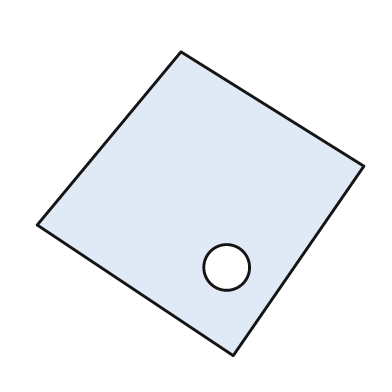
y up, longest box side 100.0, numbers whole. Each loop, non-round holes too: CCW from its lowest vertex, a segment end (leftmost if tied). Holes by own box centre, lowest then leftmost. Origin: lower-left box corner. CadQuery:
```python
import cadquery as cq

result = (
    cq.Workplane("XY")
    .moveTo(60.0, 0.0)
    .lineTo(100.0, 58.0)
    .lineTo(44.0, 93.0)
    .lineTo(0.0, 40.0)
    .close()
    .moveTo(58.0, 27.0)
    .circle(7.0)
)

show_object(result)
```